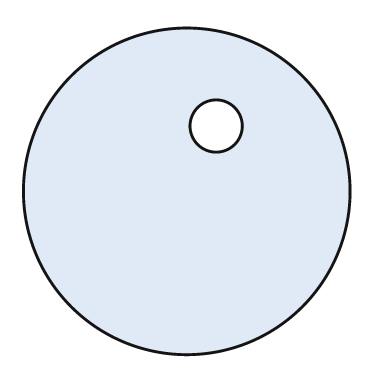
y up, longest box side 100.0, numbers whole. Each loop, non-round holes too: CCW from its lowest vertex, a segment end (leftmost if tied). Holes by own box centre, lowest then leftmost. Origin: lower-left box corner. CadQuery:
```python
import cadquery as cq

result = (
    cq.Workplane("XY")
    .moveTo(50.0, 50.0)
    .circle(50.0)
    .moveTo(59.0, 70.0)
    .circle(8.0)
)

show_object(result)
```